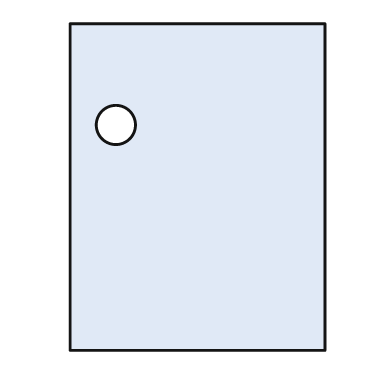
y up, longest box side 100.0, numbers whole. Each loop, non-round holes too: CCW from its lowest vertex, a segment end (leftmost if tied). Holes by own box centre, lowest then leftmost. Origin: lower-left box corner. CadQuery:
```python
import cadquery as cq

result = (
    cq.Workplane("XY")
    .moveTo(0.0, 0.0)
    .lineTo(78.0, 0.0)
    .lineTo(78.0, 100.0)
    .lineTo(0.0, 100.0)
    .close()
    .moveTo(14.0, 69.0)
    .circle(6.0)
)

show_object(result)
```